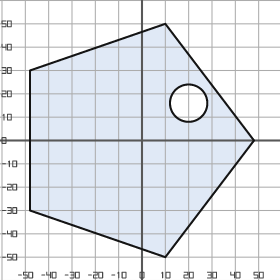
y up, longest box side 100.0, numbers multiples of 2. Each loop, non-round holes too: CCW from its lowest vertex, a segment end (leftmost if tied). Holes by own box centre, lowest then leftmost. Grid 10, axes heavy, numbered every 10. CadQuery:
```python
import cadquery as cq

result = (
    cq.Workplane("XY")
    .moveTo(10.0, -50.0)
    .lineTo(48.0, 0.0)
    .lineTo(10.0, 50.0)
    .lineTo(-48.0, 30.0)
    .lineTo(-48.0, -30.0)
    .close()
    .moveTo(20.0, 16.0)
    .circle(8.0)
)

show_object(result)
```